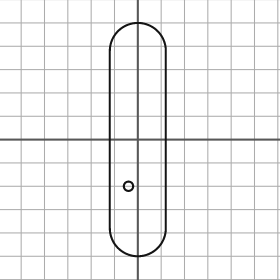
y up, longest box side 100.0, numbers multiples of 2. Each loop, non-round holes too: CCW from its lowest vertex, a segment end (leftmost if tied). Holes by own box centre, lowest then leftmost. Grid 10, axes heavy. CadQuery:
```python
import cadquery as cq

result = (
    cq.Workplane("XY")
    .moveTo(-12.0, -38.0)
    .threePointArc((0.0, -50.0), (12.0, -38.0))
    .lineTo(12.0, 38.0)
    .threePointArc((0.0, 50.0), (-12.0, 38.0))
    .close()
    .moveTo(-4.0, -20.0)
    .circle(2.0)
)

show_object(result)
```